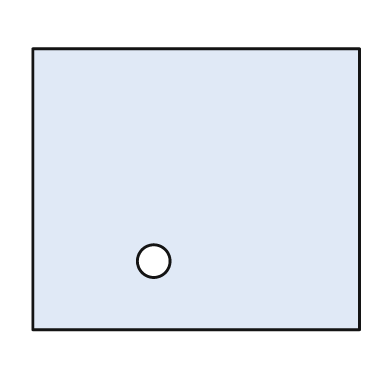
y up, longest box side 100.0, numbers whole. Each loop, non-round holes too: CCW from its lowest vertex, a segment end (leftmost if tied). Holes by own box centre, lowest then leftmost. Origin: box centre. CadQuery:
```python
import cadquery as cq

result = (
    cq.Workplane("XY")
    .moveTo(-50.0, -43.0)
    .lineTo(50.0, -43.0)
    .lineTo(50.0, 43.0)
    .lineTo(-50.0, 43.0)
    .close()
    .moveTo(-13.0, -22.0)
    .circle(5.0)
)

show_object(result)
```